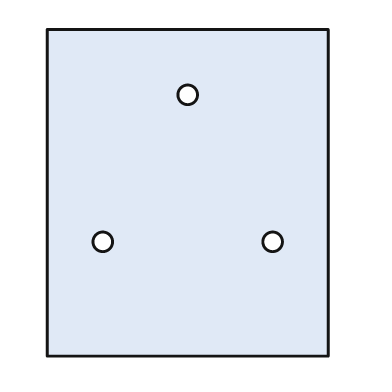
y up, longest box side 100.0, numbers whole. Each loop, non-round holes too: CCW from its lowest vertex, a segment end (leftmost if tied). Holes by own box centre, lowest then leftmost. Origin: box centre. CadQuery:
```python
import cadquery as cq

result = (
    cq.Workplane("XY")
    .moveTo(-43.0, -50.0)
    .lineTo(43.0, -50.0)
    .lineTo(43.0, 50.0)
    .lineTo(-43.0, 50.0)
    .close()
    .moveTo(-26.0, -15.0)
    .circle(3.0)
    .moveTo(26.0, -15.0)
    .circle(3.0)
    .moveTo(0.0, 30.0)
    .circle(3.0)
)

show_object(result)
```